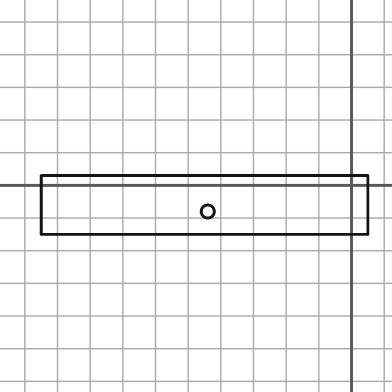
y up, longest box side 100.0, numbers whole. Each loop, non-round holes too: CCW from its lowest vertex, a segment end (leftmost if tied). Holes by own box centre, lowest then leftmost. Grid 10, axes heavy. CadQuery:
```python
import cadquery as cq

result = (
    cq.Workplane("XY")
    .moveTo(-95.0, -15.0)
    .lineTo(5.0, -15.0)
    .lineTo(5.0, 3.0)
    .lineTo(-95.0, 3.0)
    .close()
    .moveTo(-44.0, -8.0)
    .circle(2.0)
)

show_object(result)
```